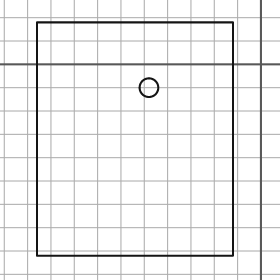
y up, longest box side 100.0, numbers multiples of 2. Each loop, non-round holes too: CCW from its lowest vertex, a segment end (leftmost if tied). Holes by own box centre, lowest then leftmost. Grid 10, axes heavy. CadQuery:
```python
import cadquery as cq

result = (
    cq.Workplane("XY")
    .moveTo(-96.0, -82.0)
    .lineTo(-12.0, -82.0)
    .lineTo(-12.0, 18.0)
    .lineTo(-96.0, 18.0)
    .close()
    .moveTo(-48.0, -10.0)
    .circle(4.0)
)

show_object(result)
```